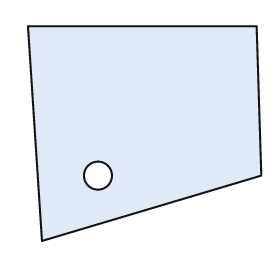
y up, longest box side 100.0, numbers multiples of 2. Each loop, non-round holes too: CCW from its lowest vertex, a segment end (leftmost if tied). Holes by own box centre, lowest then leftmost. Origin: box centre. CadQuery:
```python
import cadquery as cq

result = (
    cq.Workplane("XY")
    .moveTo(-44.0, -46.0)
    .lineTo(50.0, -18.0)
    .lineTo(48.0, 46.0)
    .lineTo(-50.0, 46.0)
    .close()
    .moveTo(-20.0, -18.0)
    .circle(6.0)
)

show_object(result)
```